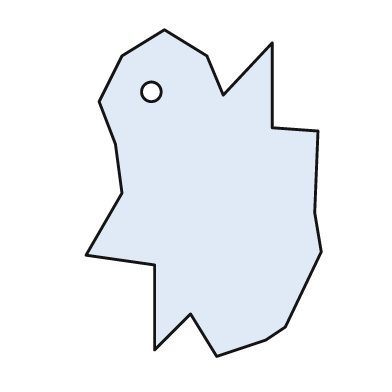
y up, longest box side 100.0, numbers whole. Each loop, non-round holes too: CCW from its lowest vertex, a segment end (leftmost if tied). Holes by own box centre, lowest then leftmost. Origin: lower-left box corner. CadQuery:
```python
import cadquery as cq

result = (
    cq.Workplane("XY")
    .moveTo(40.0, 0.0)
    .lineTo(55.0, 5.0)
    .lineTo(61.0, 9.0)
    .lineTo(72.0, 32.0)
    .lineTo(70.0, 44.0)
    .lineTo(71.0, 69.0)
    .lineTo(57.0, 70.0)
    .lineTo(57.0, 96.0)
    .lineTo(42.0, 80.0)
    .lineTo(37.0, 92.0)
    .lineTo(24.0, 100.0)
    .lineTo(11.0, 92.0)
    .lineTo(4.0, 78.0)
    .lineTo(9.0, 65.0)
    .lineTo(11.0, 50.0)
    .lineTo(0.0, 31.0)
    .lineTo(21.0, 28.0)
    .lineTo(21.0, 2.0)
    .lineTo(32.0, 13.0)
    .close()
    .moveTo(20.0, 81.0)
    .circle(3.0)
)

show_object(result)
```